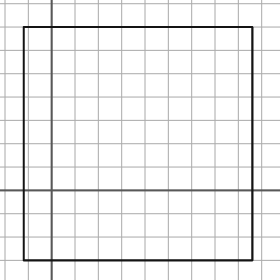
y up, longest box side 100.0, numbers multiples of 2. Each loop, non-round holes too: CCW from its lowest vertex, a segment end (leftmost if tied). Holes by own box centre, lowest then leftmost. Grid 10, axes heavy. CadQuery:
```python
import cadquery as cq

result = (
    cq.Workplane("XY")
    .moveTo(-12.0, -30.0)
    .lineTo(86.0, -30.0)
    .lineTo(86.0, 70.0)
    .lineTo(-12.0, 70.0)
    .close()
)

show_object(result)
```